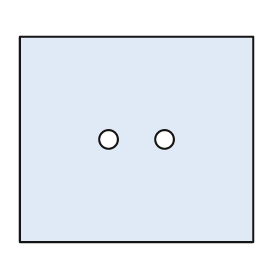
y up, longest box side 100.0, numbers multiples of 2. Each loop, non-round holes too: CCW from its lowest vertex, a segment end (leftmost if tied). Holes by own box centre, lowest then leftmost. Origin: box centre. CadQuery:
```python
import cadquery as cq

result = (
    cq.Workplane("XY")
    .moveTo(-50.0, -44.0)
    .lineTo(50.0, -44.0)
    .lineTo(50.0, 44.0)
    .lineTo(-50.0, 44.0)
    .close()
    .moveTo(-12.0, 0.0)
    .circle(4.0)
    .moveTo(12.0, 0.0)
    .circle(4.0)
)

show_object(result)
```